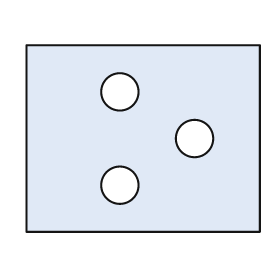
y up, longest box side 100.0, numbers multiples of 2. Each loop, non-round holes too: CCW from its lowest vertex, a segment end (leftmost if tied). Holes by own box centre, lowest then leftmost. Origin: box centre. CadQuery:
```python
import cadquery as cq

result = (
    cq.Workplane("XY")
    .moveTo(-50.0, -40.0)
    .lineTo(50.0, -40.0)
    .lineTo(50.0, 40.0)
    .lineTo(-50.0, 40.0)
    .close()
    .moveTo(-10.0, -20.0)
    .circle(8.0)
    .moveTo(22.0, 0.0)
    .circle(8.0)
    .moveTo(-10.0, 20.0)
    .circle(8.0)
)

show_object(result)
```